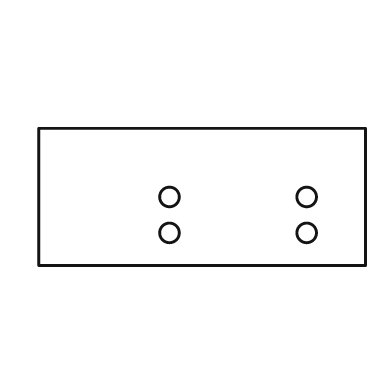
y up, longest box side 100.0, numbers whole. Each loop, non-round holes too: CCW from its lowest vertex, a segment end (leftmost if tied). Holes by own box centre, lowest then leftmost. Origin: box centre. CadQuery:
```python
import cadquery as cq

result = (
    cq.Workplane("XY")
    .moveTo(-50.0, -21.0)
    .lineTo(50.0, -21.0)
    .lineTo(50.0, 21.0)
    .lineTo(-50.0, 21.0)
    .close()
    .moveTo(-10.0, -11.0)
    .circle(3.0)
    .moveTo(32.0, -11.0)
    .circle(3.0)
    .moveTo(-10.0, 0.0)
    .circle(3.0)
    .moveTo(32.0, 0.0)
    .circle(3.0)
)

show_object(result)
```